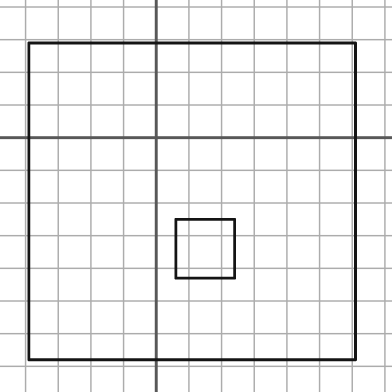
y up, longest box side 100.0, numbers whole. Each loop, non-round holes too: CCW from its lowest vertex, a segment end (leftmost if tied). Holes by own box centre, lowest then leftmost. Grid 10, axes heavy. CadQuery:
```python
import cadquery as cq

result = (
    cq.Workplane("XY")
    .moveTo(-39.0, -68.0)
    .lineTo(61.0, -68.0)
    .lineTo(61.0, 29.0)
    .lineTo(-39.0, 29.0)
    .close()
    .moveTo(6.0, -43.0)
    .lineTo(24.0, -43.0)
    .lineTo(24.0, -25.0)
    .lineTo(6.0, -25.0)
    .close()
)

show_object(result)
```